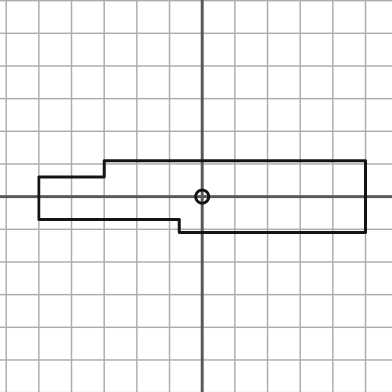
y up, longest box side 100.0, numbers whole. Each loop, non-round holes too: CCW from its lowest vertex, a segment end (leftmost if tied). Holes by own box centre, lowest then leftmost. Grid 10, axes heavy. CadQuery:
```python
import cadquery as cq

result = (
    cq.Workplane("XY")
    .moveTo(-7.0, -11.0)
    .lineTo(50.0, -11.0)
    .lineTo(50.0, 11.0)
    .lineTo(-30.0, 11.0)
    .lineTo(-30.0, 6.0)
    .lineTo(-50.0, 6.0)
    .lineTo(-50.0, -7.0)
    .lineTo(-7.0, -7.0)
    .close()
    .moveTo(0.0, 0.0)
    .circle(2.0)
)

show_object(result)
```